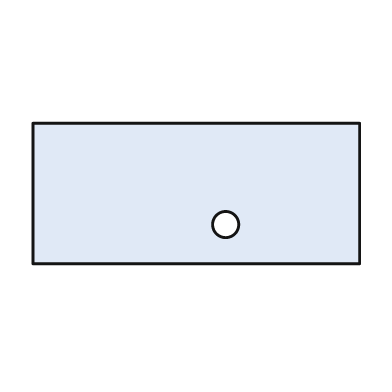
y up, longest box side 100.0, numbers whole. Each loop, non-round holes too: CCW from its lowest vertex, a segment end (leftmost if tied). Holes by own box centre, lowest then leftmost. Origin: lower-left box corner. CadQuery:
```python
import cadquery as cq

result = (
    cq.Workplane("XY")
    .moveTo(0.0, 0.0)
    .lineTo(100.0, 0.0)
    .lineTo(100.0, 43.0)
    .lineTo(0.0, 43.0)
    .close()
    .moveTo(59.0, 12.0)
    .circle(4.0)
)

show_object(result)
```